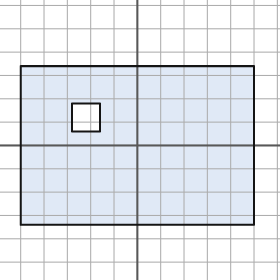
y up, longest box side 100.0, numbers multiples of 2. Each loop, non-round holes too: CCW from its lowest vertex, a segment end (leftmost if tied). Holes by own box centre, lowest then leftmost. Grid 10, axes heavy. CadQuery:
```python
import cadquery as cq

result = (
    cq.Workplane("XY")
    .moveTo(-50.0, -34.0)
    .lineTo(50.0, -34.0)
    .lineTo(50.0, 34.0)
    .lineTo(-50.0, 34.0)
    .close()
    .moveTo(-28.0, 6.0)
    .lineTo(-16.0, 6.0)
    .lineTo(-16.0, 18.0)
    .lineTo(-28.0, 18.0)
    .close()
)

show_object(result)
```